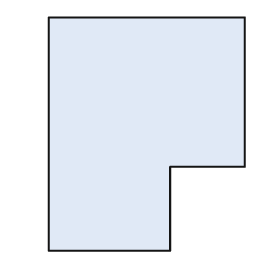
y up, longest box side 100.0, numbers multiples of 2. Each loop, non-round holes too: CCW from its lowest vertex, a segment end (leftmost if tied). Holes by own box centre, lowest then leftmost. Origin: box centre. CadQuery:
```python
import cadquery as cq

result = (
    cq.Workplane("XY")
    .moveTo(-42.0, -50.0)
    .lineTo(10.0, -50.0)
    .lineTo(10.0, -14.0)
    .lineTo(42.0, -14.0)
    .lineTo(42.0, 50.0)
    .lineTo(-42.0, 50.0)
    .close()
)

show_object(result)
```